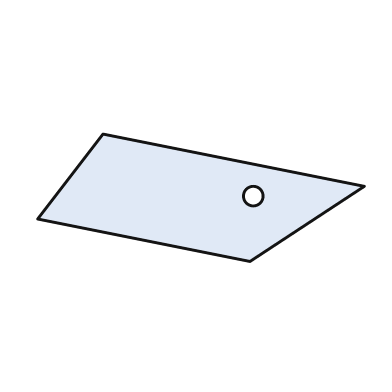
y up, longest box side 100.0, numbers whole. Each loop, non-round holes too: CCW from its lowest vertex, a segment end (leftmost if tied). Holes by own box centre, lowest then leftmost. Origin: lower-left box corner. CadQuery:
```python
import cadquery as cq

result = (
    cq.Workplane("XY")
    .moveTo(65.0, 0.0)
    .lineTo(100.0, 23.0)
    .lineTo(20.0, 39.0)
    .lineTo(0.0, 13.0)
    .close()
    .moveTo(66.0, 20.0)
    .circle(3.0)
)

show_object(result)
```